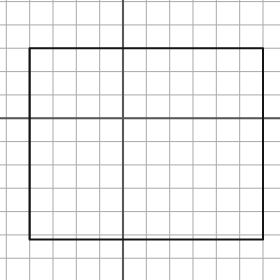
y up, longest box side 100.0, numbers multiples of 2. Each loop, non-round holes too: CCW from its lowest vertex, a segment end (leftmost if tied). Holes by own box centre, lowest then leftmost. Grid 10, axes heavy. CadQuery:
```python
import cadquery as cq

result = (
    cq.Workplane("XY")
    .moveTo(-40.0, -52.0)
    .lineTo(60.0, -52.0)
    .lineTo(60.0, 30.0)
    .lineTo(-40.0, 30.0)
    .close()
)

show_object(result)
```